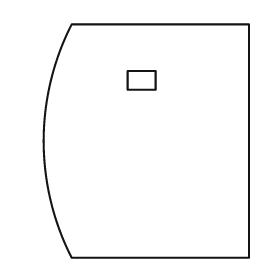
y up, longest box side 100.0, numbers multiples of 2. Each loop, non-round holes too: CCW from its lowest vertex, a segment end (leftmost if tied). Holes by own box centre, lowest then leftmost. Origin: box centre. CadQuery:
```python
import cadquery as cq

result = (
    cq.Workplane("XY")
    .moveTo(-32.0, -50.0)
    .lineTo(44.0, -50.0)
    .lineTo(44.0, 50.0)
    .lineTo(-32.0, 50.0)
    .threePointArc((-44.0, 0.0), (-32.0, -50.0))
    .close()
    .moveTo(-8.0, 22.0)
    .lineTo(4.0, 22.0)
    .lineTo(4.0, 30.0)
    .lineTo(-8.0, 30.0)
    .close()
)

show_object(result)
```